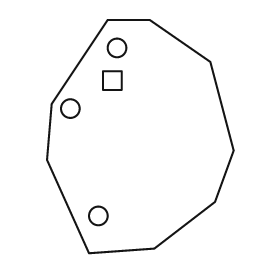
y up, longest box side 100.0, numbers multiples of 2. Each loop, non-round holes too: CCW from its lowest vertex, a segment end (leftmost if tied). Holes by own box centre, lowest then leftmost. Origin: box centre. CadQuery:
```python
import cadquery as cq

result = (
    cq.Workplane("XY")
    .moveTo(-22.0, -50.0)
    .lineTo(6.0, -48.0)
    .lineTo(32.0, -28.0)
    .lineTo(40.0, -6.0)
    .lineTo(30.0, 32.0)
    .lineTo(4.0, 50.0)
    .lineTo(-14.0, 50.0)
    .lineTo(-38.0, 14.0)
    .lineTo(-40.0, -10.0)
    .close()
    .moveTo(-18.0, -34.0)
    .circle(4.0)
    .moveTo(-30.0, 12.0)
    .circle(4.0)
    .moveTo(-16.0, 20.0)
    .lineTo(-8.0, 20.0)
    .lineTo(-8.0, 28.0)
    .lineTo(-16.0, 28.0)
    .close()
    .moveTo(-10.0, 38.0)
    .circle(4.0)
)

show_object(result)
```